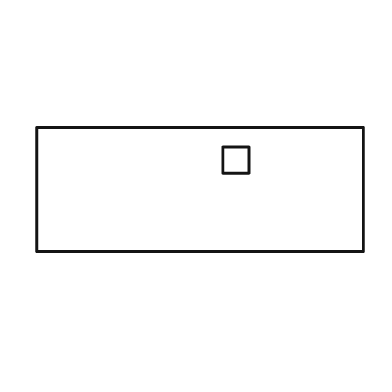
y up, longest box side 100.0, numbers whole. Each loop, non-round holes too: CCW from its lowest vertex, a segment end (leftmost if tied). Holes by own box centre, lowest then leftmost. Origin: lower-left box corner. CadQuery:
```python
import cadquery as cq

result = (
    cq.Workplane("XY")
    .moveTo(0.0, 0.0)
    .lineTo(100.0, 0.0)
    .lineTo(100.0, 38.0)
    .lineTo(0.0, 38.0)
    .close()
    .moveTo(57.0, 24.0)
    .lineTo(65.0, 24.0)
    .lineTo(65.0, 32.0)
    .lineTo(57.0, 32.0)
    .close()
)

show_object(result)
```